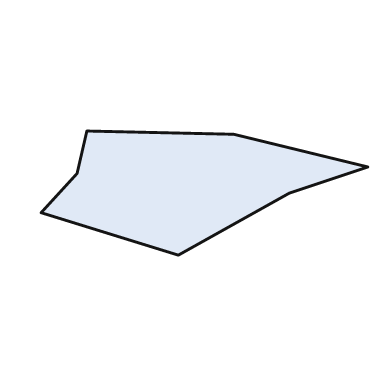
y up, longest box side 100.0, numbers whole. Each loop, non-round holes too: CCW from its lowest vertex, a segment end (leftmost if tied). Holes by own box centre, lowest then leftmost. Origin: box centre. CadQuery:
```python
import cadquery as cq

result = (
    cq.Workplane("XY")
    .moveTo(-8.0, -19.0)
    .lineTo(26.0, 0.0)
    .lineTo(50.0, 8.0)
    .lineTo(9.0, 18.0)
    .lineTo(-36.0, 19.0)
    .lineTo(-39.0, 6.0)
    .lineTo(-50.0, -6.0)
    .close()
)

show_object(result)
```